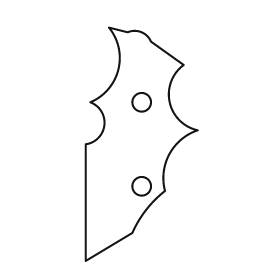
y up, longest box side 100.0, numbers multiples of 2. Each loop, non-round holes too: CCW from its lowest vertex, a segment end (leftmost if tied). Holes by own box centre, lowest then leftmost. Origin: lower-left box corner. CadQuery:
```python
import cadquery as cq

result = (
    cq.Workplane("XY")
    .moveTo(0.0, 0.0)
    .lineTo(20.0, 12.0)
    .threePointArc((26.0, 22.0), (34.0, 30.0))
    .threePointArc((36.0, 46.0), (48.0, 56.0))
    .threePointArc((36.0, 68.0), (42.0, 84.0))
    .lineTo(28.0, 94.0)
    .threePointArc((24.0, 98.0), (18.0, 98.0))
    .lineTo(10.0, 100.0)
    .threePointArc((14.0, 82.0), (2.0, 68.0))
    .threePointArc((8.0, 58.0), (0.0, 50.0))
    .close()
    .moveTo(24.0, 32.0)
    .circle(4.0)
    .moveTo(24.0, 68.0)
    .circle(4.0)
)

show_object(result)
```